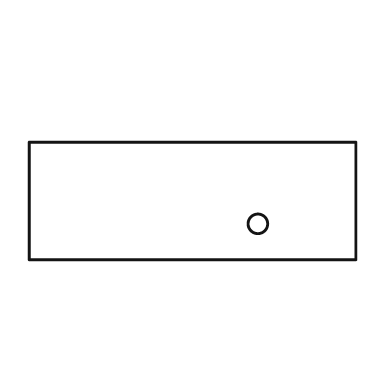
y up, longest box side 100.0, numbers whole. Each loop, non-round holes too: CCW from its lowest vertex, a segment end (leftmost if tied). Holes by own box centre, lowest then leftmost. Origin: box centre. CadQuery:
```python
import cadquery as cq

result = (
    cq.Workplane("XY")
    .moveTo(-50.0, -18.0)
    .lineTo(50.0, -18.0)
    .lineTo(50.0, 18.0)
    .lineTo(-50.0, 18.0)
    .close()
    .moveTo(20.0, -7.0)
    .circle(3.0)
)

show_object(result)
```